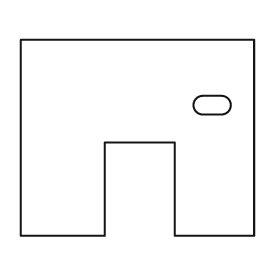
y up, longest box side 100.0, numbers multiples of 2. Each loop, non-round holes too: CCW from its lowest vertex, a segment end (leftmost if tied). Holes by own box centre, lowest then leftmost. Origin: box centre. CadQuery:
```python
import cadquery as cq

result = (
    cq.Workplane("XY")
    .moveTo(-50.0, -42.0)
    .lineTo(-14.0, -42.0)
    .lineTo(-14.0, -2.0)
    .lineTo(16.0, -2.0)
    .lineTo(16.0, -42.0)
    .lineTo(50.0, -42.0)
    .lineTo(50.0, 42.0)
    .lineTo(-50.0, 42.0)
    .close()
    .moveTo(28.0, 10.0)
    .lineTo(36.0, 10.0)
    .threePointArc((40.0, 14.0), (36.0, 18.0))
    .lineTo(28.0, 18.0)
    .threePointArc((24.0, 14.0), (28.0, 10.0))
    .close()
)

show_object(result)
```